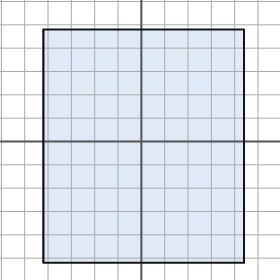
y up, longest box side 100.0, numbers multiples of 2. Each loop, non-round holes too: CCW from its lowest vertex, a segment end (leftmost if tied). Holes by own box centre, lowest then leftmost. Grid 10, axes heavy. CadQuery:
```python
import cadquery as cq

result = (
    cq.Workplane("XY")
    .moveTo(-42.0, -52.0)
    .lineTo(44.0, -52.0)
    .lineTo(44.0, 48.0)
    .lineTo(-42.0, 48.0)
    .close()
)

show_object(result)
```